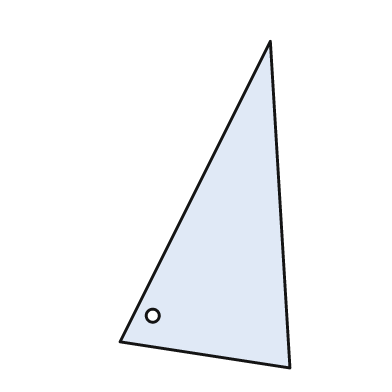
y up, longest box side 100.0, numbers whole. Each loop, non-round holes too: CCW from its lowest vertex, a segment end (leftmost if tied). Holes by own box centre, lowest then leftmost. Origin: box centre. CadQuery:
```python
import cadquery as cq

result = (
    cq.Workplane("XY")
    .moveTo(26.0, -50.0)
    .lineTo(20.0, 50.0)
    .lineTo(-26.0, -42.0)
    .close()
    .moveTo(-16.0, -34.0)
    .circle(2.0)
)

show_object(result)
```